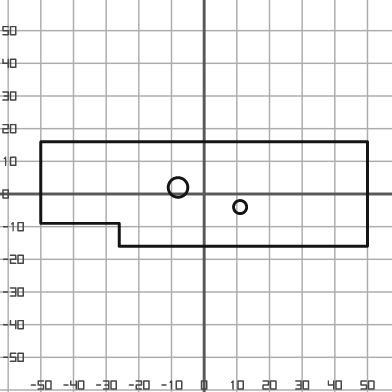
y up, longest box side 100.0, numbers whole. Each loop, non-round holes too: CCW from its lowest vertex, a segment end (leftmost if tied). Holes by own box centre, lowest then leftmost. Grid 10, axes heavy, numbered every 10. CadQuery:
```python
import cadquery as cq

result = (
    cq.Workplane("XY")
    .moveTo(-26.0, -16.0)
    .lineTo(50.0, -16.0)
    .lineTo(50.0, 16.0)
    .lineTo(-50.0, 16.0)
    .lineTo(-50.0, -9.0)
    .lineTo(-26.0, -9.0)
    .close()
    .moveTo(11.0, -4.0)
    .circle(2.0)
    .moveTo(-8.0, 2.0)
    .circle(3.0)
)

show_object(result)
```